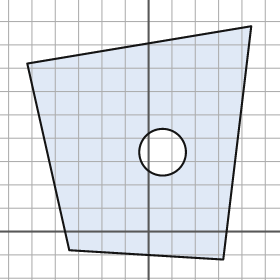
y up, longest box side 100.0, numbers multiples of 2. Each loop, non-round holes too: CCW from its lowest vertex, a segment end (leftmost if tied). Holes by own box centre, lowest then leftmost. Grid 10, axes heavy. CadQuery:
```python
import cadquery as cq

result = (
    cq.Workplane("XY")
    .moveTo(32.0, -12.0)
    .lineTo(44.0, 88.0)
    .lineTo(-52.0, 72.0)
    .lineTo(-34.0, -8.0)
    .close()
    .moveTo(6.0, 34.0)
    .circle(10.0)
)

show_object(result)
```